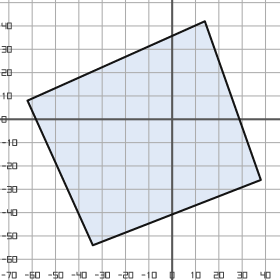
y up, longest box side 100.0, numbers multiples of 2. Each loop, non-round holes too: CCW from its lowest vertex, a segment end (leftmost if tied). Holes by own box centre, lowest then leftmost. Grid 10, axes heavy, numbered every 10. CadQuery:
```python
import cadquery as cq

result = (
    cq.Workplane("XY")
    .moveTo(-34.0, -54.0)
    .lineTo(38.0, -26.0)
    .lineTo(14.0, 42.0)
    .lineTo(-62.0, 8.0)
    .close()
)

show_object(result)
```